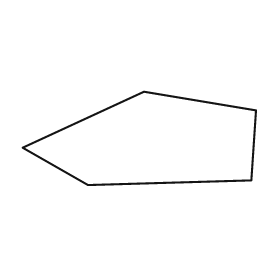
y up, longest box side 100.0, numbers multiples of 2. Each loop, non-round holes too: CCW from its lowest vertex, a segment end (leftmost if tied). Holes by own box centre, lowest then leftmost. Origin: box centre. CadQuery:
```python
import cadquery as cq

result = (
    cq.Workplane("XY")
    .moveTo(-22.0, -20.0)
    .lineTo(48.0, -18.0)
    .lineTo(50.0, 12.0)
    .lineTo(2.0, 20.0)
    .lineTo(-50.0, -4.0)
    .close()
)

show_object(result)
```